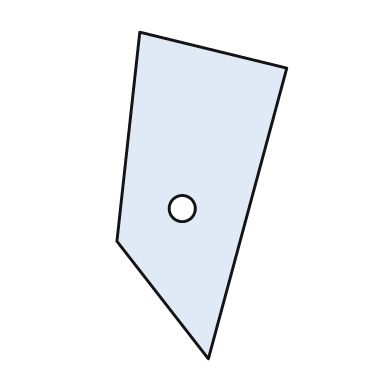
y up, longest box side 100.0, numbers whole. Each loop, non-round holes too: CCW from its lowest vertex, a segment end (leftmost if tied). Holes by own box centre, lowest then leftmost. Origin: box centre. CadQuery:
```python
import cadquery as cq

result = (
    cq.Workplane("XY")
    .moveTo(2.0, -50.0)
    .lineTo(26.0, 39.0)
    .lineTo(-19.0, 50.0)
    .lineTo(-26.0, -14.0)
    .close()
    .moveTo(-6.0, -4.0)
    .circle(4.0)
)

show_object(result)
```